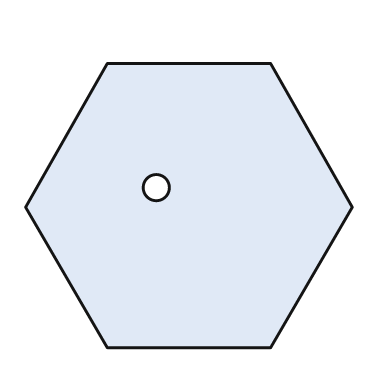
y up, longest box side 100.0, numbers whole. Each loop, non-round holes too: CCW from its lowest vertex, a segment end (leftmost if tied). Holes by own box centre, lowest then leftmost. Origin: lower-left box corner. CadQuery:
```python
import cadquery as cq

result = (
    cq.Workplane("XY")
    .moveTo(25.0, 0.0)
    .lineTo(75.0, 0.0)
    .lineTo(100.0, 43.0)
    .lineTo(75.0, 87.0)
    .lineTo(25.0, 87.0)
    .lineTo(0.0, 43.0)
    .close()
    .moveTo(40.0, 49.0)
    .circle(4.0)
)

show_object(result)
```